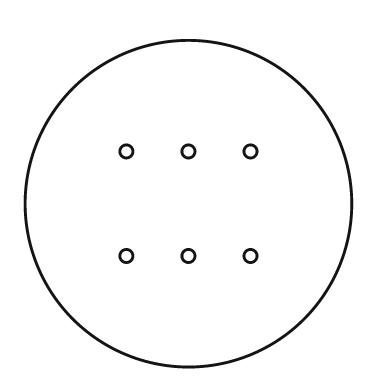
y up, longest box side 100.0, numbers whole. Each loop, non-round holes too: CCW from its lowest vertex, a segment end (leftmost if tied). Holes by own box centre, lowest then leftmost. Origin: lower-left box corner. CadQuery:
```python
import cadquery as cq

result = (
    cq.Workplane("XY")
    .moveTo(50.0, 50.0)
    .circle(50.0)
    .moveTo(31.0, 34.0)
    .circle(2.0)
    .moveTo(50.0, 34.0)
    .circle(2.0)
    .moveTo(69.0, 34.0)
    .circle(2.0)
    .moveTo(31.0, 66.0)
    .circle(2.0)
    .moveTo(50.0, 66.0)
    .circle(2.0)
    .moveTo(69.0, 66.0)
    .circle(2.0)
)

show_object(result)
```